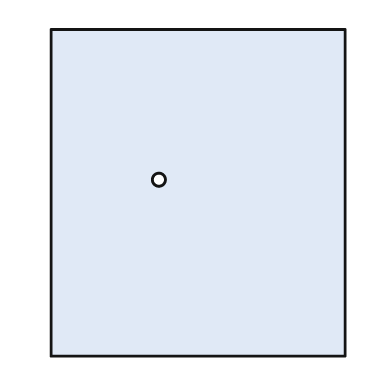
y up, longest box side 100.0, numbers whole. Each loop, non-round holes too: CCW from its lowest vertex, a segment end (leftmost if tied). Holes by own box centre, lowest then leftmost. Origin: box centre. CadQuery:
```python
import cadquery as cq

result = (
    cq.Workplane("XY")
    .moveTo(-45.0, -50.0)
    .lineTo(45.0, -50.0)
    .lineTo(45.0, 50.0)
    .lineTo(-45.0, 50.0)
    .close()
    .moveTo(-12.0, 4.0)
    .circle(2.0)
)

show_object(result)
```